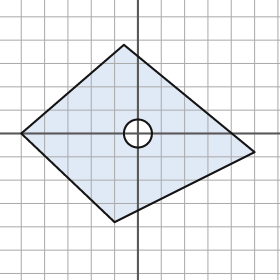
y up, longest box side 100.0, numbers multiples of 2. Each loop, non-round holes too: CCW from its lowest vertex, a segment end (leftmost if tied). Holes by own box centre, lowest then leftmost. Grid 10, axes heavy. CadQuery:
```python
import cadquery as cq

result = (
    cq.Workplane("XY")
    .moveTo(-10.0, -38.0)
    .lineTo(50.0, -8.0)
    .lineTo(-6.0, 38.0)
    .lineTo(-50.0, 0.0)
    .close()
    .moveTo(0.0, 0.0)
    .circle(6.0)
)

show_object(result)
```